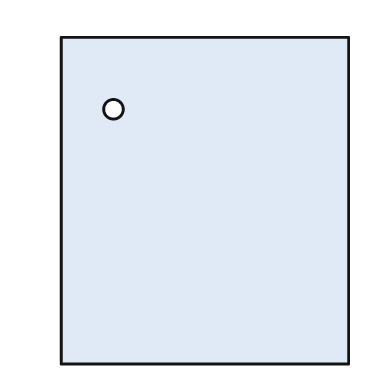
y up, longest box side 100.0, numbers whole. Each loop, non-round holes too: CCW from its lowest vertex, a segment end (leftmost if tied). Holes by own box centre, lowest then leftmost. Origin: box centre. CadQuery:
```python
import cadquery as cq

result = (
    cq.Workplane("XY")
    .moveTo(-44.0, -50.0)
    .lineTo(44.0, -50.0)
    .lineTo(44.0, 50.0)
    .lineTo(-44.0, 50.0)
    .close()
    .moveTo(-28.0, 28.0)
    .circle(3.0)
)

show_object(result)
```